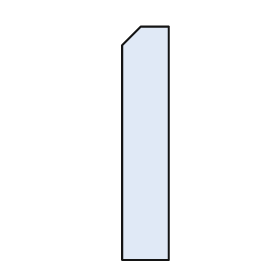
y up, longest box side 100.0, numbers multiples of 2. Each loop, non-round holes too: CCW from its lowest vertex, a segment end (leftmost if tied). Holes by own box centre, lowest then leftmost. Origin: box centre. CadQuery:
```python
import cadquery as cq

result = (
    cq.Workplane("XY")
    .moveTo(-10.0, -50.0)
    .lineTo(10.0, -50.0)
    .lineTo(10.0, 50.0)
    .lineTo(-2.0, 50.0)
    .lineTo(-10.0, 42.0)
    .close()
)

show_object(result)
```